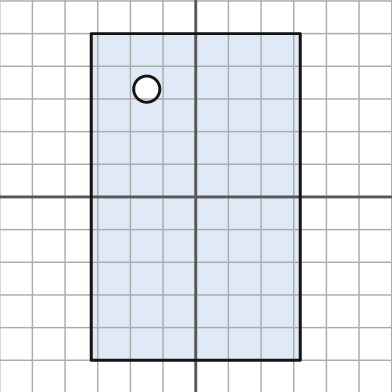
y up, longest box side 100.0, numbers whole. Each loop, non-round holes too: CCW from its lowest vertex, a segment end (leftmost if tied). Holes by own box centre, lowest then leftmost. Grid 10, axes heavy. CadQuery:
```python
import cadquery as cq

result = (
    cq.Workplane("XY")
    .moveTo(-32.0, -50.0)
    .lineTo(32.0, -50.0)
    .lineTo(32.0, 50.0)
    .lineTo(-32.0, 50.0)
    .close()
    .moveTo(-15.0, 33.0)
    .circle(4.0)
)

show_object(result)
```